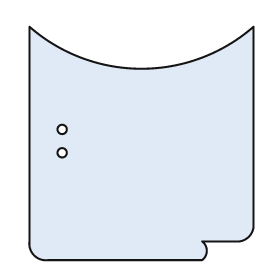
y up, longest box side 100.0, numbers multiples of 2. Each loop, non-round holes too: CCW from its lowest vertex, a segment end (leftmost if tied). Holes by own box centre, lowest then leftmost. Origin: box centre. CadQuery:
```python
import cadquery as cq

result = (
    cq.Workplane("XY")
    .moveTo(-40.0, -50.0)
    .lineTo(26.0, -50.0)
    .threePointArc((28.0, -46.0), (26.0, -42.0))
    .lineTo(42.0, -42.0)
    .threePointArc((46.0, -40.0), (48.0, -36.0))
    .lineTo(48.0, 50.0)
    .threePointArc((0.0, 32.0), (-48.0, 50.0))
    .lineTo(-48.0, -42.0)
    .threePointArc((-46.0, -48.0), (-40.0, -50.0))
    .close()
    .moveTo(-34.0, -4.0)
    .circle(2.0)
    .moveTo(-34.0, 6.0)
    .circle(2.0)
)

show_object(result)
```